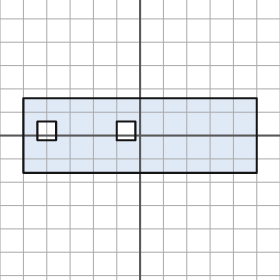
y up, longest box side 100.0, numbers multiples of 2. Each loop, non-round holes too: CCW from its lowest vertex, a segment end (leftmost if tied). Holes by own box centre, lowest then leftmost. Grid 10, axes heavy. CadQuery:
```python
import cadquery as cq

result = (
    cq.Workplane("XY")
    .moveTo(-50.0, -16.0)
    .lineTo(50.0, -16.0)
    .lineTo(50.0, 16.0)
    .lineTo(-50.0, 16.0)
    .close()
    .moveTo(-44.0, -2.0)
    .lineTo(-36.0, -2.0)
    .lineTo(-36.0, 6.0)
    .lineTo(-44.0, 6.0)
    .close()
    .moveTo(-10.0, -2.0)
    .lineTo(-2.0, -2.0)
    .lineTo(-2.0, 6.0)
    .lineTo(-10.0, 6.0)
    .close()
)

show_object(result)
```